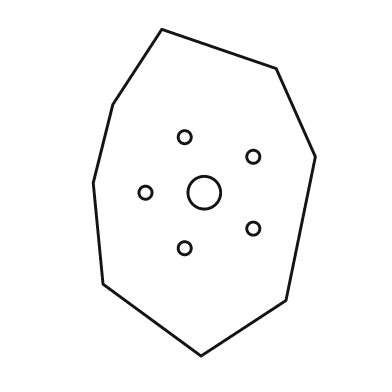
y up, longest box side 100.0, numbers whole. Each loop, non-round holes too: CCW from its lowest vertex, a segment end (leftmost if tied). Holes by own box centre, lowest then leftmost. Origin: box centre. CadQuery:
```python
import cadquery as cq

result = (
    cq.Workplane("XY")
    .moveTo(-1.0, -50.0)
    .lineTo(25.0, -33.0)
    .lineTo(34.0, 11.0)
    .lineTo(22.0, 38.0)
    .lineTo(-13.0, 50.0)
    .lineTo(-28.0, 27.0)
    .lineTo(-34.0, 3.0)
    .lineTo(-31.0, -28.0)
    .close()
    .moveTo(-6.0, -17.0)
    .circle(2.0)
    .moveTo(15.0, -11.0)
    .circle(2.0)
    .moveTo(-18.0, 0.0)
    .circle(2.0)
    .moveTo(0.0, 0.0)
    .circle(5.0)
    .moveTo(15.0, 11.0)
    .circle(2.0)
    .moveTo(-6.0, 17.0)
    .circle(2.0)
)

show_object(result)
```